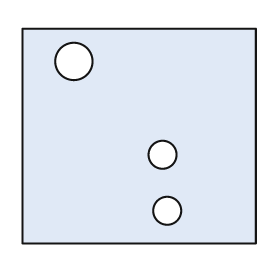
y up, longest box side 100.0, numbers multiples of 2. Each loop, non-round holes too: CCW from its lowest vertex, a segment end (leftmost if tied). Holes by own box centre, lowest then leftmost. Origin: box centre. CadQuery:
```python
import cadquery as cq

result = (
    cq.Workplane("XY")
    .moveTo(-50.0, -46.0)
    .lineTo(50.0, -46.0)
    .lineTo(50.0, 46.0)
    .lineTo(-50.0, 46.0)
    .close()
    .moveTo(12.0, -32.0)
    .circle(6.0)
    .moveTo(10.0, -8.0)
    .circle(6.0)
    .moveTo(-28.0, 32.0)
    .circle(8.0)
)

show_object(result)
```